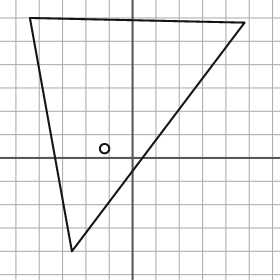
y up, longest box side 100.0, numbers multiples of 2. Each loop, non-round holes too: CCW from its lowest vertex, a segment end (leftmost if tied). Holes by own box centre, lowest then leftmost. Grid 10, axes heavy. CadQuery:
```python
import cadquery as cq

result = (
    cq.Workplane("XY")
    .moveTo(-26.0, -40.0)
    .lineTo(48.0, 58.0)
    .lineTo(-44.0, 60.0)
    .close()
    .moveTo(-12.0, 4.0)
    .circle(2.0)
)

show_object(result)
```